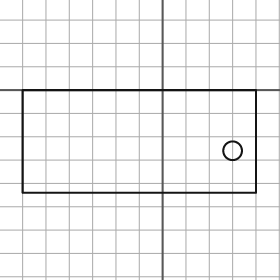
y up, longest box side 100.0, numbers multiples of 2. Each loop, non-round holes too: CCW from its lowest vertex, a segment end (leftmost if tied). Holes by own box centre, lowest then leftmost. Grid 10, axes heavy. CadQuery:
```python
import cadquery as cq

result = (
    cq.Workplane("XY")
    .moveTo(-60.0, -44.0)
    .lineTo(40.0, -44.0)
    .lineTo(40.0, 0.0)
    .lineTo(-60.0, 0.0)
    .close()
    .moveTo(30.0, -26.0)
    .circle(4.0)
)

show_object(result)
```